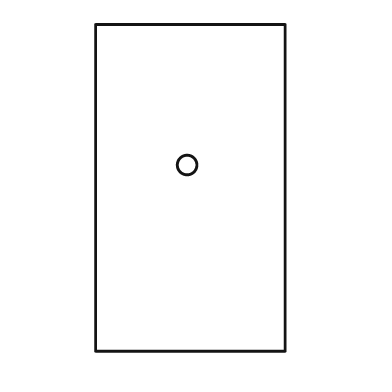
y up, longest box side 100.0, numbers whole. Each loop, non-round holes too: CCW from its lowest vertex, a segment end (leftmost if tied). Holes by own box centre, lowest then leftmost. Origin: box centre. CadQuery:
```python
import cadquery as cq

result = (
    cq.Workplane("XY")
    .moveTo(-29.0, -50.0)
    .lineTo(29.0, -50.0)
    .lineTo(29.0, 50.0)
    .lineTo(-29.0, 50.0)
    .close()
    .moveTo(-1.0, 7.0)
    .circle(3.0)
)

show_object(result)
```